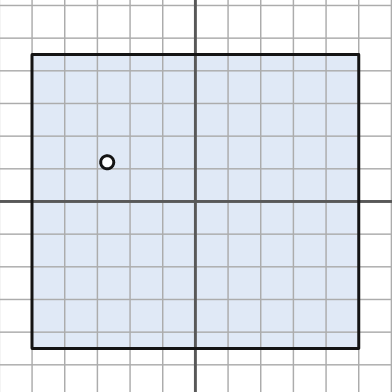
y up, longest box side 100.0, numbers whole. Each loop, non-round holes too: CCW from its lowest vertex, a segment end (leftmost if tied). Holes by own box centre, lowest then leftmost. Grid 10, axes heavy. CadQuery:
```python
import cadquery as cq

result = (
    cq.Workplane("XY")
    .moveTo(-50.0, -45.0)
    .lineTo(50.0, -45.0)
    .lineTo(50.0, 45.0)
    .lineTo(-50.0, 45.0)
    .close()
    .moveTo(-27.0, 12.0)
    .circle(2.0)
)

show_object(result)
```